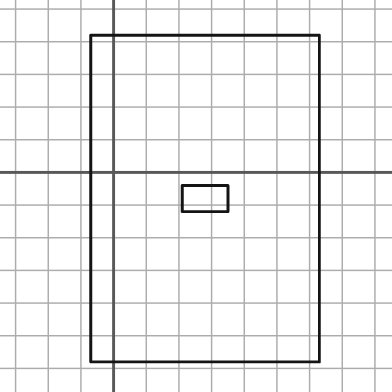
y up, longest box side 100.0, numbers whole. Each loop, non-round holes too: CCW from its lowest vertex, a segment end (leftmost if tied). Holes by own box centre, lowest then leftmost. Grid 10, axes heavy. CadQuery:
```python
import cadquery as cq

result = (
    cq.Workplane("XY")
    .moveTo(-7.0, -58.0)
    .lineTo(63.0, -58.0)
    .lineTo(63.0, 42.0)
    .lineTo(-7.0, 42.0)
    .close()
    .moveTo(21.0, -12.0)
    .lineTo(35.0, -12.0)
    .lineTo(35.0, -4.0)
    .lineTo(21.0, -4.0)
    .close()
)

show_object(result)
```